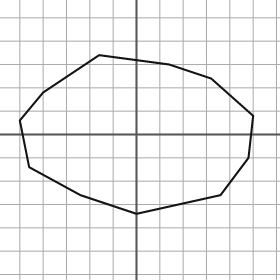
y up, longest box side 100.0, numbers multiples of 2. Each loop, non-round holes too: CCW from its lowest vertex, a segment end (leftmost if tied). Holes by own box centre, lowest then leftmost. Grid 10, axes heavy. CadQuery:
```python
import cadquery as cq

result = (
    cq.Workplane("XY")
    .moveTo(0.0, -34.0)
    .lineTo(36.0, -26.0)
    .lineTo(48.0, -10.0)
    .lineTo(50.0, 8.0)
    .lineTo(32.0, 24.0)
    .lineTo(14.0, 30.0)
    .lineTo(-16.0, 34.0)
    .lineTo(-40.0, 18.0)
    .lineTo(-50.0, 6.0)
    .lineTo(-46.0, -14.0)
    .lineTo(-24.0, -26.0)
    .close()
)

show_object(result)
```